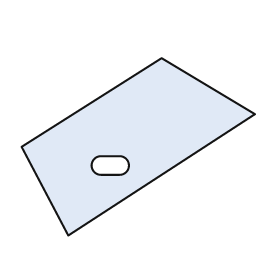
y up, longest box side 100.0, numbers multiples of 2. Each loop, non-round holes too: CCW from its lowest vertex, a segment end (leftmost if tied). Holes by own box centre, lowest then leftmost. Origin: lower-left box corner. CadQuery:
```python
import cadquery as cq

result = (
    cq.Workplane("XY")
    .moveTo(20.0, 0.0)
    .lineTo(100.0, 52.0)
    .lineTo(60.0, 76.0)
    .lineTo(0.0, 38.0)
    .close()
    .moveTo(34.0, 26.0)
    .lineTo(42.0, 26.0)
    .threePointArc((46.0, 30.0), (42.0, 34.0))
    .lineTo(34.0, 34.0)
    .threePointArc((30.0, 30.0), (34.0, 26.0))
    .close()
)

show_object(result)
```